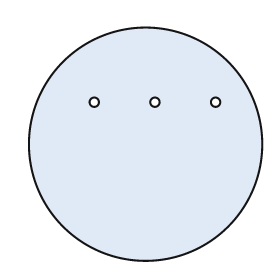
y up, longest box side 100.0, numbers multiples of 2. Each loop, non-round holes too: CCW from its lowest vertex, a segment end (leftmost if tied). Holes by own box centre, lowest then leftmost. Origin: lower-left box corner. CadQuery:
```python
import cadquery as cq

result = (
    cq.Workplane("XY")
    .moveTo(50.0, 50.0)
    .circle(50.0)
    .moveTo(28.0, 68.0)
    .circle(2.0)
    .moveTo(54.0, 68.0)
    .circle(2.0)
    .moveTo(80.0, 68.0)
    .circle(2.0)
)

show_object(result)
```